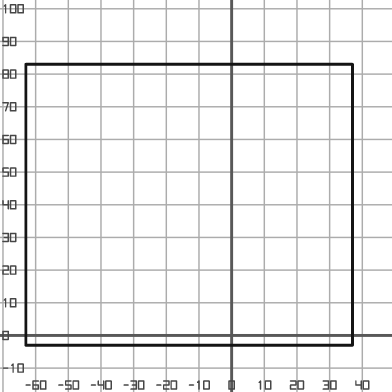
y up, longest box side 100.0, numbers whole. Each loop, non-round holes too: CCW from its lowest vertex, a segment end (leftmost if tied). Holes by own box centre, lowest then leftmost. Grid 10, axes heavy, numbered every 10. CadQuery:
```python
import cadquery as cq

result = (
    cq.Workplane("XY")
    .moveTo(-63.0, -3.0)
    .lineTo(37.0, -3.0)
    .lineTo(37.0, 83.0)
    .lineTo(-63.0, 83.0)
    .close()
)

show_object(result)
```